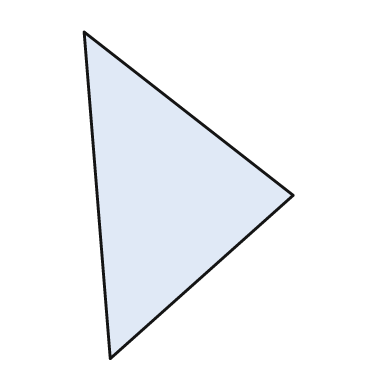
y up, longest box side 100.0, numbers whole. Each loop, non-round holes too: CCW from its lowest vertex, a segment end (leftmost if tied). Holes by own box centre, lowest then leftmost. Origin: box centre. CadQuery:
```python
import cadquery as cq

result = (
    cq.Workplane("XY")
    .moveTo(-24.0, -50.0)
    .lineTo(32.0, 0.0)
    .lineTo(-32.0, 50.0)
    .close()
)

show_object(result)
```